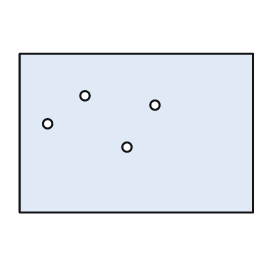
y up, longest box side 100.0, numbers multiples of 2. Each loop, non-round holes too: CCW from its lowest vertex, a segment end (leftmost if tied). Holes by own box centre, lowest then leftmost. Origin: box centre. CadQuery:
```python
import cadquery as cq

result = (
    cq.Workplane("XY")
    .moveTo(-50.0, -34.0)
    .lineTo(50.0, -34.0)
    .lineTo(50.0, 34.0)
    .lineTo(-50.0, 34.0)
    .close()
    .moveTo(-4.0, -6.0)
    .circle(2.0)
    .moveTo(-38.0, 4.0)
    .circle(2.0)
    .moveTo(8.0, 12.0)
    .circle(2.0)
    .moveTo(-22.0, 16.0)
    .circle(2.0)
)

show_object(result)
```